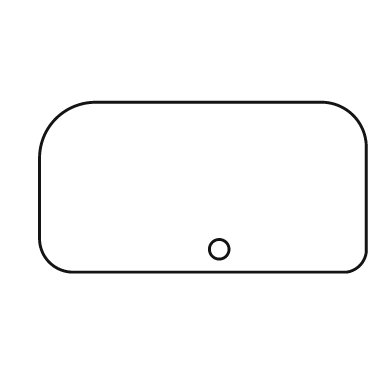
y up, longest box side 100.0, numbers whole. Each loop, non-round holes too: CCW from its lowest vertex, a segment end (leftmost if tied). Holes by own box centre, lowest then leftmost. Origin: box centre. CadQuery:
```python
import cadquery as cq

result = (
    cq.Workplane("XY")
    .moveTo(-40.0, -26.0)
    .lineTo(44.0, -26.0)
    .threePointArc((48.0, -24.0), (50.0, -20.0))
    .lineTo(50.0, 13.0)
    .threePointArc((46.0, 22.0), (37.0, 26.0))
    .lineTo(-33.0, 26.0)
    .threePointArc((-45.0, 21.0), (-50.0, 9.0))
    .lineTo(-50.0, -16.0)
    .threePointArc((-47.0, -23.0), (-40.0, -26.0))
    .close()
    .moveTo(5.0, -19.0)
    .circle(3.0)
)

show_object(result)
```